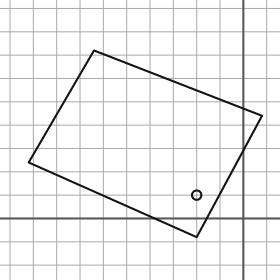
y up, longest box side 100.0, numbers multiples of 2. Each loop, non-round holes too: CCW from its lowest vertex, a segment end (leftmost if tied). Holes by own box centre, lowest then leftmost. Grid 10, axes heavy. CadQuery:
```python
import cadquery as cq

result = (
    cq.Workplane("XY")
    .moveTo(-20.0, -8.0)
    .lineTo(8.0, 44.0)
    .lineTo(-64.0, 72.0)
    .lineTo(-92.0, 24.0)
    .close()
    .moveTo(-20.0, 10.0)
    .circle(2.0)
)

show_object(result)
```